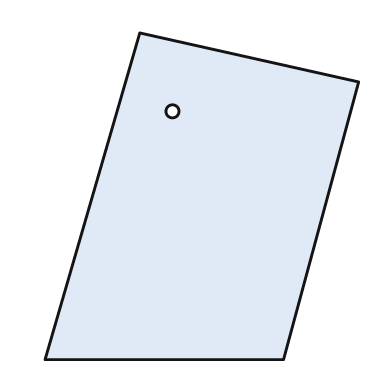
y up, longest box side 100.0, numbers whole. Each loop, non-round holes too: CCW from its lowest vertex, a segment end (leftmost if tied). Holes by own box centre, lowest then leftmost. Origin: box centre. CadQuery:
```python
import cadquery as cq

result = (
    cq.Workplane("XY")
    .moveTo(-48.0, -50.0)
    .lineTo(25.0, -50.0)
    .lineTo(48.0, 35.0)
    .lineTo(-19.0, 50.0)
    .close()
    .moveTo(-9.0, 26.0)
    .circle(2.0)
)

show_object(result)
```